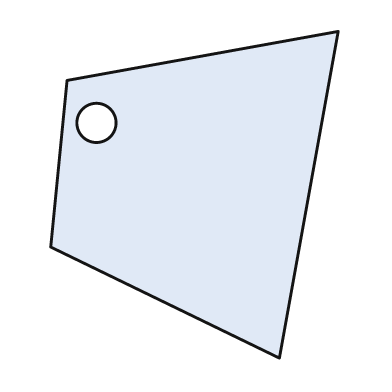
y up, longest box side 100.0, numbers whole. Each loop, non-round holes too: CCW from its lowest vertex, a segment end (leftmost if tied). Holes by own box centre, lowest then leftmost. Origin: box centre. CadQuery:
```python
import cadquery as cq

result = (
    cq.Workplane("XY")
    .moveTo(26.0, -50.0)
    .lineTo(44.0, 50.0)
    .lineTo(-39.0, 35.0)
    .lineTo(-44.0, -16.0)
    .close()
    .moveTo(-30.0, 22.0)
    .circle(6.0)
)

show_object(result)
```